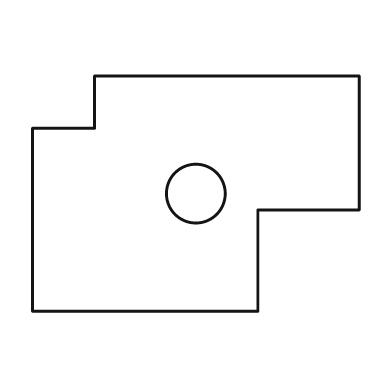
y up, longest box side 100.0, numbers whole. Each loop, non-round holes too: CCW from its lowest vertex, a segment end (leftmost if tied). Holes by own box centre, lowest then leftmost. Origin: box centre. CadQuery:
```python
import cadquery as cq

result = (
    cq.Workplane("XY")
    .moveTo(-50.0, -36.0)
    .lineTo(19.0, -36.0)
    .lineTo(19.0, -5.0)
    .lineTo(50.0, -5.0)
    .lineTo(50.0, 36.0)
    .lineTo(-31.0, 36.0)
    .lineTo(-31.0, 20.0)
    .lineTo(-50.0, 20.0)
    .close()
    .moveTo(0.0, 0.0)
    .circle(9.0)
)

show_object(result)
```